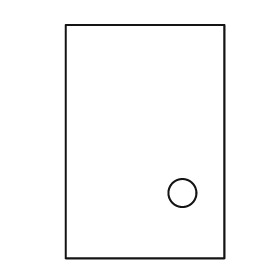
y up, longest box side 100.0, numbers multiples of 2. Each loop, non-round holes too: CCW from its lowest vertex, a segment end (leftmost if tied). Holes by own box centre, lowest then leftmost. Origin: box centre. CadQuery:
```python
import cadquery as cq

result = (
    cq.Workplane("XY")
    .moveTo(-34.0, -50.0)
    .lineTo(34.0, -50.0)
    .lineTo(34.0, 50.0)
    .lineTo(-34.0, 50.0)
    .close()
    .moveTo(16.0, -22.0)
    .circle(6.0)
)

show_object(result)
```